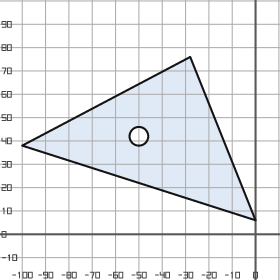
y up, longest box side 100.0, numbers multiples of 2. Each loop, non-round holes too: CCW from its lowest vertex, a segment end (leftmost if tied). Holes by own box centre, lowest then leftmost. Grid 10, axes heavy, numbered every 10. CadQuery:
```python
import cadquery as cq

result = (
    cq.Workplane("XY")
    .moveTo(0.0, 6.0)
    .lineTo(-28.0, 76.0)
    .lineTo(-100.0, 38.0)
    .close()
    .moveTo(-50.0, 42.0)
    .circle(4.0)
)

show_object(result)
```